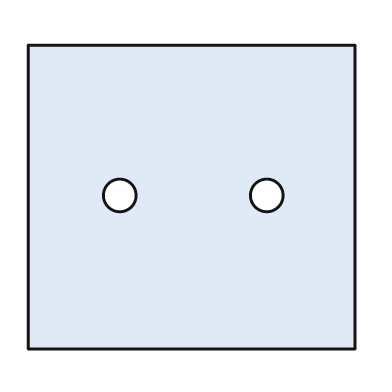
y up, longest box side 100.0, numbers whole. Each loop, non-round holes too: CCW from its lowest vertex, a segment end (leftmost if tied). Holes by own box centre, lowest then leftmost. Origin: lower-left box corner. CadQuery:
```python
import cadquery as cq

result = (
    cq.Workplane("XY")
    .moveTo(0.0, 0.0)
    .lineTo(100.0, 0.0)
    .lineTo(100.0, 93.0)
    .lineTo(0.0, 93.0)
    .close()
    .moveTo(28.0, 47.0)
    .circle(5.0)
    .moveTo(73.0, 47.0)
    .circle(5.0)
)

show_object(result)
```